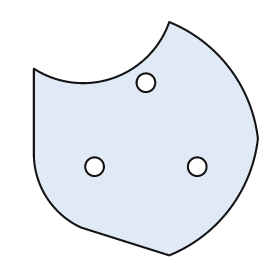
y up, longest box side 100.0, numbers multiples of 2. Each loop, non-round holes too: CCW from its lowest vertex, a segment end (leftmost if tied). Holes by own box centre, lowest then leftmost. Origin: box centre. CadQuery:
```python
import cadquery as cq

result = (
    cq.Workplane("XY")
    .moveTo(10.0, -50.0)
    .threePointArc((36.0, -30.0), (48.0, 0.0))
    .threePointArc((36.0, 30.0), (10.0, 50.0))
    .threePointArc((-14.0, 26.0), (-48.0, 30.0))
    .lineTo(-48.0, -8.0)
    .threePointArc((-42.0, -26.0), (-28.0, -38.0))
    .close()
    .moveTo(-22.0, -12.0)
    .circle(4.0)
    .moveTo(22.0, -12.0)
    .circle(4.0)
    .moveTo(0.0, 24.0)
    .circle(4.0)
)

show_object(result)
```